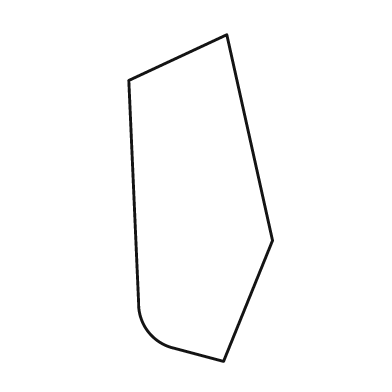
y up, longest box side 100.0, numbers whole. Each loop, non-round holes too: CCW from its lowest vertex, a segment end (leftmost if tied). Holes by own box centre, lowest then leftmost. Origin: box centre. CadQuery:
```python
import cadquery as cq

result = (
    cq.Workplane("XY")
    .moveTo(7.0, -50.0)
    .lineTo(22.0, -13.0)
    .lineTo(8.0, 50.0)
    .lineTo(-22.0, 36.0)
    .lineTo(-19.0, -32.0)
    .threePointArc((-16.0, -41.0), (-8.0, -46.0))
    .close()
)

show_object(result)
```